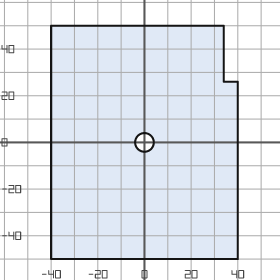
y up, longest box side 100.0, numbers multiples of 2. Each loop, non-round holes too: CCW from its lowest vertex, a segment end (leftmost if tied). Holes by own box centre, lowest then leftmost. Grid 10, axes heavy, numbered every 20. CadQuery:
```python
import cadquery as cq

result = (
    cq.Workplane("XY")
    .moveTo(-40.0, -50.0)
    .lineTo(40.0, -50.0)
    .lineTo(40.0, 26.0)
    .lineTo(34.0, 26.0)
    .lineTo(34.0, 50.0)
    .lineTo(-40.0, 50.0)
    .close()
    .moveTo(0.0, 0.0)
    .circle(4.0)
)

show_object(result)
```